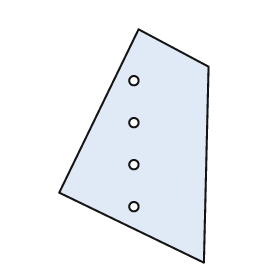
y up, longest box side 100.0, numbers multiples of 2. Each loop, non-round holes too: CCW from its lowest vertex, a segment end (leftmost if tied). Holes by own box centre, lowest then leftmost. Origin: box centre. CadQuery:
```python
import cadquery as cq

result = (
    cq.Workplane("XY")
    .moveTo(30.0, -50.0)
    .lineTo(32.0, 34.0)
    .lineTo(2.0, 50.0)
    .lineTo(-32.0, -20.0)
    .close()
    .moveTo(0.0, -26.0)
    .circle(2.0)
    .moveTo(0.0, -8.0)
    .circle(2.0)
    .moveTo(0.0, 10.0)
    .circle(2.0)
    .moveTo(0.0, 28.0)
    .circle(2.0)
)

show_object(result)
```